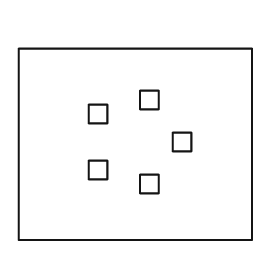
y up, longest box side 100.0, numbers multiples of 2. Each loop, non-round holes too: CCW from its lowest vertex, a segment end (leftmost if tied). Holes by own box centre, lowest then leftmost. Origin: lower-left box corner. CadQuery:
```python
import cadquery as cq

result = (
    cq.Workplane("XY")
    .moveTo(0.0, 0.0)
    .lineTo(100.0, 0.0)
    .lineTo(100.0, 82.0)
    .lineTo(0.0, 82.0)
    .close()
    .moveTo(52.0, 20.0)
    .lineTo(60.0, 20.0)
    .lineTo(60.0, 28.0)
    .lineTo(52.0, 28.0)
    .close()
    .moveTo(30.0, 26.0)
    .lineTo(38.0, 26.0)
    .lineTo(38.0, 34.0)
    .lineTo(30.0, 34.0)
    .close()
    .moveTo(66.0, 38.0)
    .lineTo(74.0, 38.0)
    .lineTo(74.0, 46.0)
    .lineTo(66.0, 46.0)
    .close()
    .moveTo(30.0, 50.0)
    .lineTo(38.0, 50.0)
    .lineTo(38.0, 58.0)
    .lineTo(30.0, 58.0)
    .close()
    .moveTo(52.0, 56.0)
    .lineTo(60.0, 56.0)
    .lineTo(60.0, 64.0)
    .lineTo(52.0, 64.0)
    .close()
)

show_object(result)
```